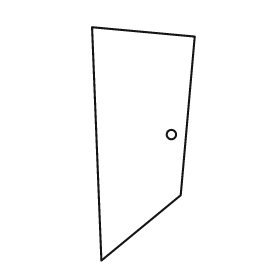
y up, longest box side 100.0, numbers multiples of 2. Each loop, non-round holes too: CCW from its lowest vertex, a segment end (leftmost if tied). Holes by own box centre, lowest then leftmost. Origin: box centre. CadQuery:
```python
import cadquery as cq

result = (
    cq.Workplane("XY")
    .moveTo(-18.0, -50.0)
    .lineTo(16.0, -22.0)
    .lineTo(22.0, 46.0)
    .lineTo(-22.0, 50.0)
    .close()
    .moveTo(12.0, 4.0)
    .circle(2.0)
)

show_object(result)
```